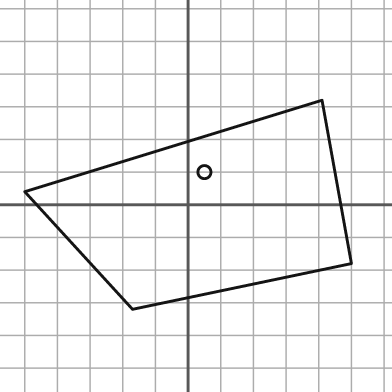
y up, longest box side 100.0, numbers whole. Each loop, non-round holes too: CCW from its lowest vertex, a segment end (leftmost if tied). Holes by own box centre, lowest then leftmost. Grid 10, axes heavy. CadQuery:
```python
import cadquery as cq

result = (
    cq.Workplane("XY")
    .moveTo(-17.0, -32.0)
    .lineTo(50.0, -18.0)
    .lineTo(41.0, 32.0)
    .lineTo(-50.0, 4.0)
    .close()
    .moveTo(5.0, 10.0)
    .circle(2.0)
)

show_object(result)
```